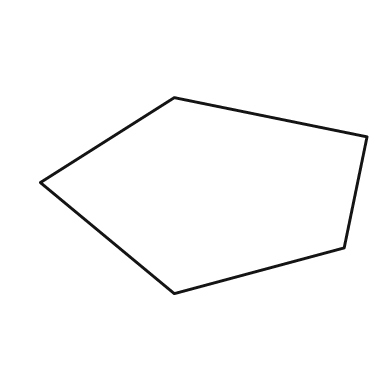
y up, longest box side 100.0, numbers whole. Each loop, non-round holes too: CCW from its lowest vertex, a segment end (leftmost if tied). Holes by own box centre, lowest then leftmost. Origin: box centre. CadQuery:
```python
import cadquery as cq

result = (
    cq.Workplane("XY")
    .moveTo(-9.0, -30.0)
    .lineTo(43.0, -16.0)
    .lineTo(50.0, 18.0)
    .lineTo(-9.0, 30.0)
    .lineTo(-50.0, 4.0)
    .close()
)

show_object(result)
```